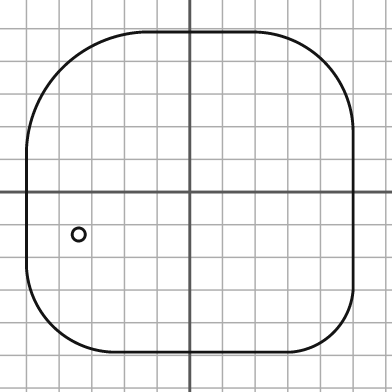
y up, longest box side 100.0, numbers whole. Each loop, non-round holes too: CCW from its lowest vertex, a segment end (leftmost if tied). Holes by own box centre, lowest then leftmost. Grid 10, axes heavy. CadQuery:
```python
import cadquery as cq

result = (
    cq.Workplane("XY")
    .moveTo(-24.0, -49.0)
    .lineTo(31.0, -49.0)
    .threePointArc((44.0, -43.0), (50.0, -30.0))
    .lineTo(50.0, 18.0)
    .threePointArc((41.0, 40.0), (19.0, 49.0))
    .lineTo(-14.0, 49.0)
    .threePointArc((-39.0, 38.0), (-50.0, 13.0))
    .lineTo(-50.0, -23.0)
    .threePointArc((-42.0, -41.0), (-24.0, -49.0))
    .close()
    .moveTo(-34.0, -13.0)
    .circle(2.0)
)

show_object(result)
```